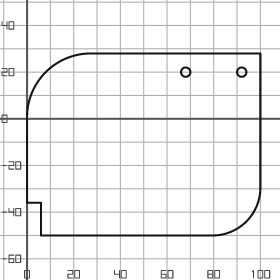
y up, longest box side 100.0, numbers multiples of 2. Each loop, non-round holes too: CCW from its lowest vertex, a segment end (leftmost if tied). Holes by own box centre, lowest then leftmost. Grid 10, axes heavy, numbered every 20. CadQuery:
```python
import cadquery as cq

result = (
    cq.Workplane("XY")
    .moveTo(6.0, -50.0)
    .lineTo(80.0, -50.0)
    .threePointArc((94.0, -44.0), (100.0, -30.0))
    .lineTo(100.0, 28.0)
    .lineTo(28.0, 28.0)
    .threePointArc((8.0, 20.0), (0.0, 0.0))
    .lineTo(0.0, -36.0)
    .lineTo(6.0, -36.0)
    .close()
    .moveTo(68.0, 20.0)
    .circle(2.0)
    .moveTo(92.0, 20.0)
    .circle(2.0)
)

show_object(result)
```